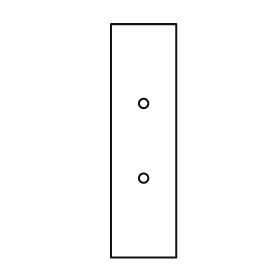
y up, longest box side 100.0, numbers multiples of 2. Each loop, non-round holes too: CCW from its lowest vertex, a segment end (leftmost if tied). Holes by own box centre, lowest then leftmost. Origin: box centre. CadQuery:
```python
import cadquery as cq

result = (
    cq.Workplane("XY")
    .moveTo(-14.0, -50.0)
    .lineTo(14.0, -50.0)
    .lineTo(14.0, 50.0)
    .lineTo(-14.0, 50.0)
    .close()
    .moveTo(0.0, -16.0)
    .circle(2.0)
    .moveTo(0.0, 16.0)
    .circle(2.0)
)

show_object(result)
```